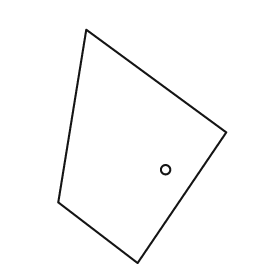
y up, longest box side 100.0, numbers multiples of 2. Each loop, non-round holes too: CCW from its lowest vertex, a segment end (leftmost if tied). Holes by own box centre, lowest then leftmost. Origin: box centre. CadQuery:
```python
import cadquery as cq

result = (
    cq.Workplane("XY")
    .moveTo(-2.0, -50.0)
    .lineTo(36.0, 6.0)
    .lineTo(-24.0, 50.0)
    .lineTo(-36.0, -24.0)
    .close()
    .moveTo(10.0, -10.0)
    .circle(2.0)
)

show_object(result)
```